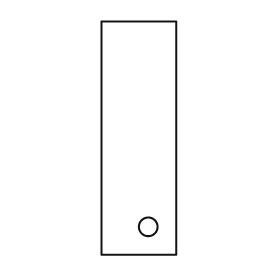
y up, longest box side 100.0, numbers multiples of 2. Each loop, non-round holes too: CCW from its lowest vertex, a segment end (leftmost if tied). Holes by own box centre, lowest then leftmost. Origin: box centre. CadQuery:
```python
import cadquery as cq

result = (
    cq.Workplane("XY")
    .moveTo(-16.0, -50.0)
    .lineTo(16.0, -50.0)
    .lineTo(16.0, 50.0)
    .lineTo(-16.0, 50.0)
    .close()
    .moveTo(4.0, -38.0)
    .circle(4.0)
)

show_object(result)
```